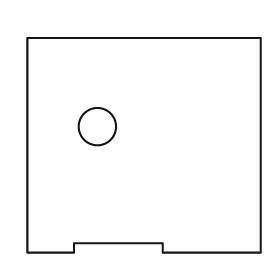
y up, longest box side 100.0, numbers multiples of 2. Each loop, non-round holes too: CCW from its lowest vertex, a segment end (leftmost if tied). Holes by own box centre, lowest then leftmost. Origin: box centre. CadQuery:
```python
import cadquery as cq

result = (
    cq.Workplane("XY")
    .moveTo(-50.0, -46.0)
    .lineTo(-30.0, -46.0)
    .lineTo(-30.0, -42.0)
    .lineTo(8.0, -42.0)
    .lineTo(8.0, -46.0)
    .lineTo(50.0, -46.0)
    .lineTo(50.0, 46.0)
    .lineTo(-50.0, 46.0)
    .close()
    .moveTo(-20.0, 8.0)
    .circle(8.0)
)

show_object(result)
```